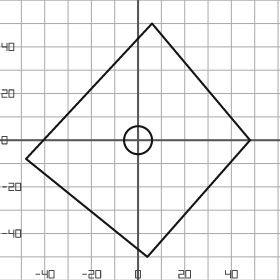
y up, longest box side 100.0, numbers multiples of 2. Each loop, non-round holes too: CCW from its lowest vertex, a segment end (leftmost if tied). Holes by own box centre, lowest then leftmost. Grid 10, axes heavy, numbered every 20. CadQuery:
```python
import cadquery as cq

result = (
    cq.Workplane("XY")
    .moveTo(4.0, -50.0)
    .lineTo(48.0, 0.0)
    .lineTo(6.0, 50.0)
    .lineTo(-48.0, -8.0)
    .close()
    .moveTo(0.0, 0.0)
    .circle(6.0)
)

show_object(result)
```